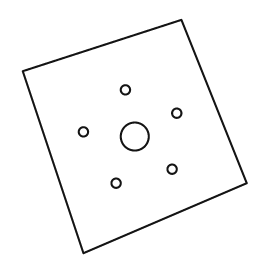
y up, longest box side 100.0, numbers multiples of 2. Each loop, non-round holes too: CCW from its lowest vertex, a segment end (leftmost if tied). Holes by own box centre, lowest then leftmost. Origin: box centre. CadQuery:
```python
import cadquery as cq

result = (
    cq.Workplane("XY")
    .moveTo(-22.0, -50.0)
    .lineTo(48.0, -20.0)
    .lineTo(20.0, 50.0)
    .lineTo(-48.0, 28.0)
    .close()
    .moveTo(-8.0, -20.0)
    .circle(2.0)
    .moveTo(16.0, -14.0)
    .circle(2.0)
    .moveTo(0.0, 0.0)
    .circle(6.0)
    .moveTo(-22.0, 2.0)
    .circle(2.0)
    .moveTo(18.0, 10.0)
    .circle(2.0)
    .moveTo(-4.0, 20.0)
    .circle(2.0)
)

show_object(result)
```